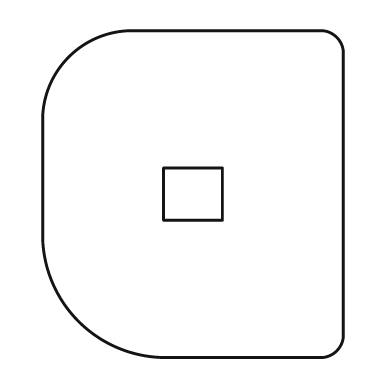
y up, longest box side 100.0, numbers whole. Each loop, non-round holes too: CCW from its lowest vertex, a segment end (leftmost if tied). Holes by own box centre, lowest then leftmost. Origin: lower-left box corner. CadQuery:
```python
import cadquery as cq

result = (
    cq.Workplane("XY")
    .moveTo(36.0, 0.0)
    .lineTo(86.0, 0.0)
    .threePointArc((90.0, 2.0), (92.0, 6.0))
    .lineTo(92.0, 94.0)
    .threePointArc((90.0, 98.0), (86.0, 100.0))
    .lineTo(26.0, 100.0)
    .threePointArc((8.0, 92.0), (0.0, 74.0))
    .lineTo(0.0, 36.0)
    .threePointArc((11.0, 11.0), (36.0, 0.0))
    .close()
    .moveTo(37.0, 42.0)
    .lineTo(55.0, 42.0)
    .lineTo(55.0, 58.0)
    .lineTo(37.0, 58.0)
    .close()
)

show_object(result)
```